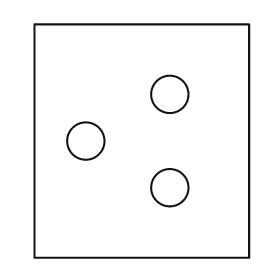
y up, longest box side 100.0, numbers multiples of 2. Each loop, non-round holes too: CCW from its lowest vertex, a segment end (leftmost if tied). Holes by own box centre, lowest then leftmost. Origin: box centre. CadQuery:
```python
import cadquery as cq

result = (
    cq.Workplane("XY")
    .moveTo(-46.0, -50.0)
    .lineTo(46.0, -50.0)
    .lineTo(46.0, 50.0)
    .lineTo(-46.0, 50.0)
    .close()
    .moveTo(12.0, -20.0)
    .circle(8.0)
    .moveTo(-24.0, 0.0)
    .circle(8.0)
    .moveTo(12.0, 20.0)
    .circle(8.0)
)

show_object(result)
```